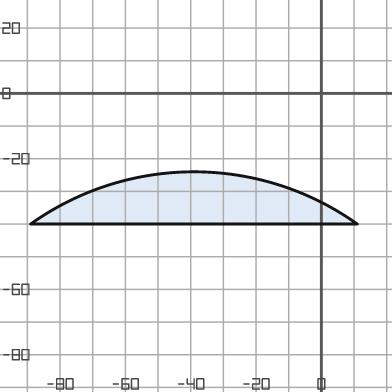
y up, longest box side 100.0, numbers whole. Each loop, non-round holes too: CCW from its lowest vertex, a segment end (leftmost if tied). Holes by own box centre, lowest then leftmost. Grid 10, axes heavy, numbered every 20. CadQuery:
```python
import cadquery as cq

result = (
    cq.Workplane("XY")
    .moveTo(-89.0, -40.0)
    .lineTo(11.0, -40.0)
    .threePointArc((-39.0, -24.0), (-89.0, -40.0))
    .close()
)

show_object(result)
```